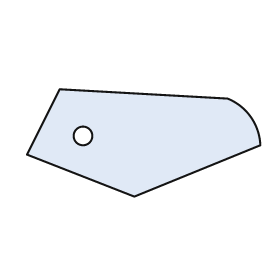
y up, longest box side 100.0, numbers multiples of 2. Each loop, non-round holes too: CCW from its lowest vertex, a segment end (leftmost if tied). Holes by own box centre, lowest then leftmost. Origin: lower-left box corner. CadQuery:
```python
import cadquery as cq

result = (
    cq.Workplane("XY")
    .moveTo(46.0, 0.0)
    .lineTo(100.0, 22.0)
    .threePointArc((96.0, 34.0), (86.0, 42.0))
    .lineTo(14.0, 46.0)
    .lineTo(0.0, 18.0)
    .close()
    .moveTo(24.0, 26.0)
    .circle(4.0)
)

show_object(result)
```